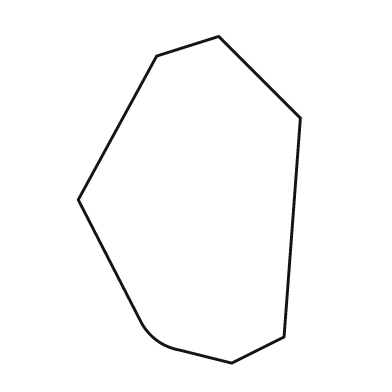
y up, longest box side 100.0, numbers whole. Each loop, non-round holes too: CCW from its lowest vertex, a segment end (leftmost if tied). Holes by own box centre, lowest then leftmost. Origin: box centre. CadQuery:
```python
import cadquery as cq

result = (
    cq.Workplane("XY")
    .moveTo(13.0, -50.0)
    .lineTo(29.0, -42.0)
    .lineTo(34.0, 25.0)
    .lineTo(9.0, 50.0)
    .lineTo(-10.0, 44.0)
    .lineTo(-34.0, 0.0)
    .lineTo(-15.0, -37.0)
    .threePointArc((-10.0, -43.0), (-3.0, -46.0))
    .close()
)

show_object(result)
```